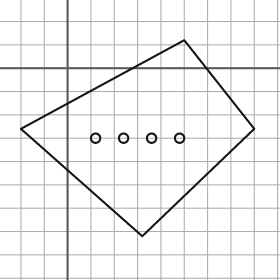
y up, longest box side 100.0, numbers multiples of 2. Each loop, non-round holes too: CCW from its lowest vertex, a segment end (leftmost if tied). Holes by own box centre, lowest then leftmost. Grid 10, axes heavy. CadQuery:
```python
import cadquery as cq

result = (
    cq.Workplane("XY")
    .moveTo(32.0, -72.0)
    .lineTo(80.0, -26.0)
    .lineTo(50.0, 12.0)
    .lineTo(-20.0, -26.0)
    .close()
    .moveTo(12.0, -30.0)
    .circle(2.0)
    .moveTo(24.0, -30.0)
    .circle(2.0)
    .moveTo(36.0, -30.0)
    .circle(2.0)
    .moveTo(48.0, -30.0)
    .circle(2.0)
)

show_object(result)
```